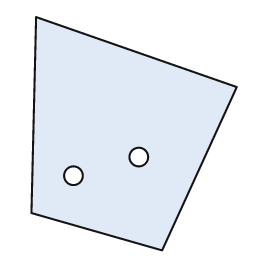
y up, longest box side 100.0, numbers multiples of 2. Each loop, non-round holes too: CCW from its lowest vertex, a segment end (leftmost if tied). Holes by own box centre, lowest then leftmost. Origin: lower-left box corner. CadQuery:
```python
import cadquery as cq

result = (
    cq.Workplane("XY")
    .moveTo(56.0, 0.0)
    .lineTo(88.0, 70.0)
    .lineTo(2.0, 100.0)
    .lineTo(0.0, 16.0)
    .close()
    .moveTo(18.0, 32.0)
    .circle(4.0)
    .moveTo(46.0, 40.0)
    .circle(4.0)
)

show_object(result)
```